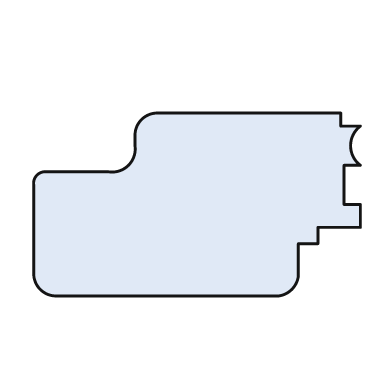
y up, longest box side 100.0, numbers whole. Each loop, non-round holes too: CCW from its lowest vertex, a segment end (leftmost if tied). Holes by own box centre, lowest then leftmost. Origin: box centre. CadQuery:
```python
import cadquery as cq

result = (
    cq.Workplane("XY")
    .moveTo(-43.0, -28.0)
    .lineTo(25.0, -28.0)
    .threePointArc((29.0, -26.0), (31.0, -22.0))
    .lineTo(31.0, -12.0)
    .lineTo(37.0, -12.0)
    .lineTo(37.0, -7.0)
    .lineTo(50.0, -7.0)
    .lineTo(50.0, 0.0)
    .lineTo(45.0, 0.0)
    .lineTo(45.0, 12.0)
    .lineTo(50.0, 12.0)
    .threePointArc((47.0, 18.0), (50.0, 24.0))
    .lineTo(44.0, 24.0)
    .lineTo(44.0, 28.0)
    .lineTo(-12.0, 28.0)
    .threePointArc((-17.0, 26.0), (-19.0, 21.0))
    .lineTo(-19.0, 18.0)
    .threePointArc((-21.0, 12.0), (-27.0, 10.0))
    .lineTo(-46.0, 10.0)
    .threePointArc((-49.0, 9.0), (-50.0, 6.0))
    .lineTo(-50.0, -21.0)
    .threePointArc((-48.0, -26.0), (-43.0, -28.0))
    .close()
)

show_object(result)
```